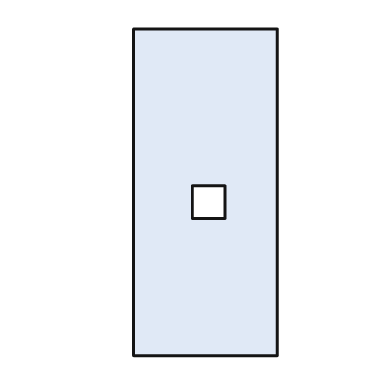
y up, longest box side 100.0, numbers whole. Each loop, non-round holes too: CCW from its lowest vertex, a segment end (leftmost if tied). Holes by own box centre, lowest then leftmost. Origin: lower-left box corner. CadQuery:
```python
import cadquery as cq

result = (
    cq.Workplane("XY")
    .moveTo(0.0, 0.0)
    .lineTo(44.0, 0.0)
    .lineTo(44.0, 100.0)
    .lineTo(0.0, 100.0)
    .close()
    .moveTo(18.0, 42.0)
    .lineTo(28.0, 42.0)
    .lineTo(28.0, 52.0)
    .lineTo(18.0, 52.0)
    .close()
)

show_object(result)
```